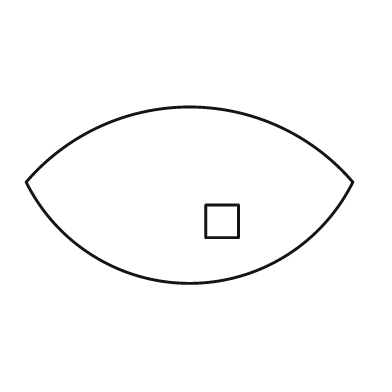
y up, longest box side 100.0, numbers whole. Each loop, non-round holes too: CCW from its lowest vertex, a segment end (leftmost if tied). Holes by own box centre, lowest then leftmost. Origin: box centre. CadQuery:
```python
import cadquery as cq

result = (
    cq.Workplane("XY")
    .moveTo(-50.0, 4.0)
    .threePointArc((0.0, -27.0), (50.0, 4.0))
    .threePointArc((0.0, 27.0), (-50.0, 4.0))
    .close()
    .moveTo(5.0, -13.0)
    .lineTo(15.0, -13.0)
    .lineTo(15.0, -3.0)
    .lineTo(5.0, -3.0)
    .close()
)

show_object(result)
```